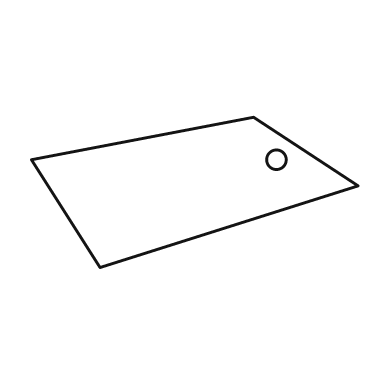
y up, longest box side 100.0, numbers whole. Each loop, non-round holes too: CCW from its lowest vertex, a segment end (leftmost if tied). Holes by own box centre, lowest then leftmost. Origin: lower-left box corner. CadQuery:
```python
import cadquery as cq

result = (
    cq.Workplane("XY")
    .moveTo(21.0, 0.0)
    .lineTo(100.0, 25.0)
    .lineTo(68.0, 46.0)
    .lineTo(0.0, 33.0)
    .close()
    .moveTo(75.0, 33.0)
    .circle(3.0)
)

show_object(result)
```